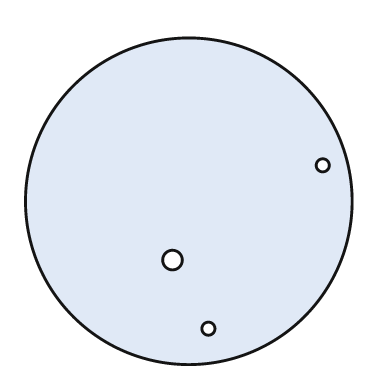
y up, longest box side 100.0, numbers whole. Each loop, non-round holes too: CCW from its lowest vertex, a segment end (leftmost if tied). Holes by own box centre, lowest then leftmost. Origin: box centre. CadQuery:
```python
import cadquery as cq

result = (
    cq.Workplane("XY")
    .moveTo(0.0, 0.0)
    .circle(50.0)
    .moveTo(6.0, -39.0)
    .circle(2.0)
    .moveTo(-5.0, -18.0)
    .circle(3.0)
    .moveTo(41.0, 11.0)
    .circle(2.0)
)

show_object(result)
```